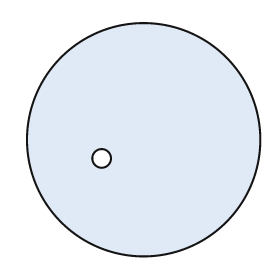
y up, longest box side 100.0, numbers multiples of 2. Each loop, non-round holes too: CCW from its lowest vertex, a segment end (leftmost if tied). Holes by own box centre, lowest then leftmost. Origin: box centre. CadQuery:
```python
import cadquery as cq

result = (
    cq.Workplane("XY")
    .moveTo(0.0, 0.0)
    .circle(50.0)
    .moveTo(-18.0, -8.0)
    .circle(4.0)
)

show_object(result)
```